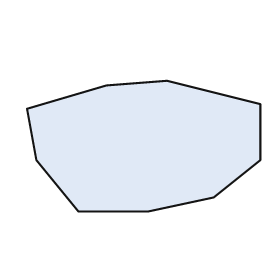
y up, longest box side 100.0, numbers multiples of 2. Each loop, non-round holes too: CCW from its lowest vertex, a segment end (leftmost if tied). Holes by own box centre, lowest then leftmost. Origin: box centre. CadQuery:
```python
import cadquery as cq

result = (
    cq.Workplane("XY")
    .moveTo(-28.0, -28.0)
    .lineTo(2.0, -28.0)
    .lineTo(30.0, -22.0)
    .lineTo(50.0, -6.0)
    .lineTo(50.0, 18.0)
    .lineTo(10.0, 28.0)
    .lineTo(-16.0, 26.0)
    .lineTo(-50.0, 16.0)
    .lineTo(-46.0, -6.0)
    .close()
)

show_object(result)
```